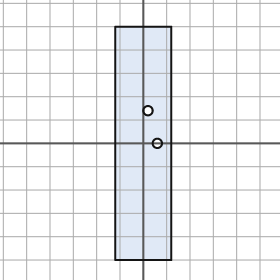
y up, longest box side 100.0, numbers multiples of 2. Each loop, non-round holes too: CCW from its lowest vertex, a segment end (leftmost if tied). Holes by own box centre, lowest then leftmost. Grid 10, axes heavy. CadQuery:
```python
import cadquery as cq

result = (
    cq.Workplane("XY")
    .moveTo(-12.0, -50.0)
    .lineTo(12.0, -50.0)
    .lineTo(12.0, 50.0)
    .lineTo(-12.0, 50.0)
    .close()
    .moveTo(6.0, 0.0)
    .circle(2.0)
    .moveTo(2.0, 14.0)
    .circle(2.0)
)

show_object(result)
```